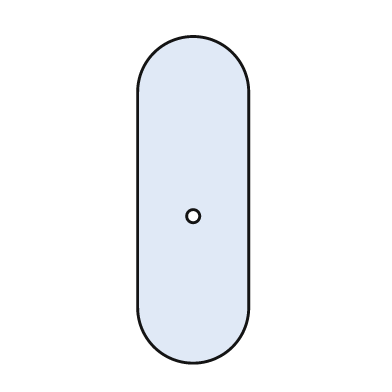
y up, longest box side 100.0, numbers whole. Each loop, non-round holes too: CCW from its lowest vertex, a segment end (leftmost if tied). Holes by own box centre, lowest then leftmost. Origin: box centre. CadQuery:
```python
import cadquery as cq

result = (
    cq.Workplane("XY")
    .moveTo(-17.0, -33.0)
    .threePointArc((0.0, -50.0), (17.0, -33.0))
    .lineTo(17.0, 33.0)
    .threePointArc((0.0, 50.0), (-17.0, 33.0))
    .close()
    .moveTo(0.0, -5.0)
    .circle(2.0)
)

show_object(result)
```